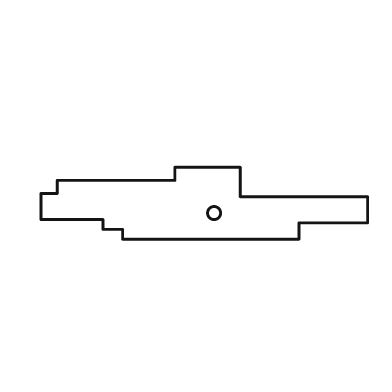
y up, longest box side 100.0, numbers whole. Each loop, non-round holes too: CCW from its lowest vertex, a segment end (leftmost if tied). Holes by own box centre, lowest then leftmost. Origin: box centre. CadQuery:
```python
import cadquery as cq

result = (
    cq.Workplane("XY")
    .moveTo(-25.0, -11.0)
    .lineTo(29.0, -11.0)
    .lineTo(29.0, -6.0)
    .lineTo(50.0, -6.0)
    .lineTo(50.0, 2.0)
    .lineTo(11.0, 2.0)
    .lineTo(11.0, 11.0)
    .lineTo(-9.0, 11.0)
    .lineTo(-9.0, 7.0)
    .lineTo(-45.0, 7.0)
    .lineTo(-45.0, 3.0)
    .lineTo(-50.0, 3.0)
    .lineTo(-50.0, -5.0)
    .lineTo(-31.0, -5.0)
    .lineTo(-31.0, -8.0)
    .lineTo(-25.0, -8.0)
    .close()
    .moveTo(3.0, -3.0)
    .circle(2.0)
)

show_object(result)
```